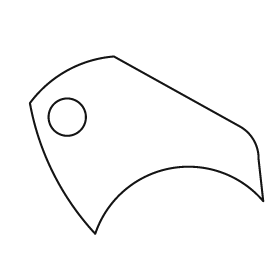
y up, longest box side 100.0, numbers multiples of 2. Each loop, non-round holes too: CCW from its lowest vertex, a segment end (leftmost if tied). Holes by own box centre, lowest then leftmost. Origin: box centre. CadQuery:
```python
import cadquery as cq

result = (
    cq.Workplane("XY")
    .moveTo(-22.0, -38.0)
    .threePointArc((10.0, -10.0), (50.0, -24.0))
    .lineTo(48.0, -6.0)
    .threePointArc((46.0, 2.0), (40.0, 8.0))
    .lineTo(-14.0, 38.0)
    .threePointArc((-34.0, 32.0), (-50.0, 18.0))
    .threePointArc((-40.0, -12.0), (-22.0, -38.0))
    .close()
    .moveTo(-34.0, 12.0)
    .circle(8.0)
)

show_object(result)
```